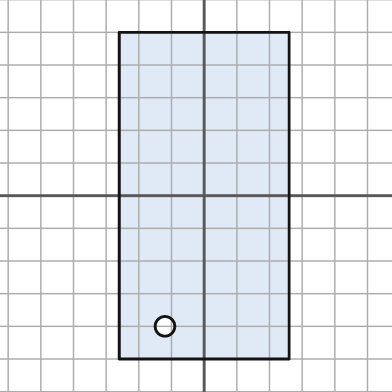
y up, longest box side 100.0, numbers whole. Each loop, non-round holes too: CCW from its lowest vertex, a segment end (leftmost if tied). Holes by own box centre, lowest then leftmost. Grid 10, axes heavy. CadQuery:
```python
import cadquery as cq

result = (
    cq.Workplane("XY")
    .moveTo(-26.0, -50.0)
    .lineTo(26.0, -50.0)
    .lineTo(26.0, 50.0)
    .lineTo(-26.0, 50.0)
    .close()
    .moveTo(-12.0, -40.0)
    .circle(3.0)
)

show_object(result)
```